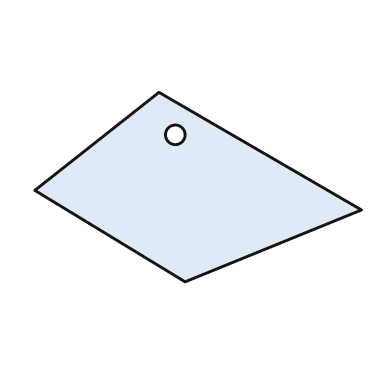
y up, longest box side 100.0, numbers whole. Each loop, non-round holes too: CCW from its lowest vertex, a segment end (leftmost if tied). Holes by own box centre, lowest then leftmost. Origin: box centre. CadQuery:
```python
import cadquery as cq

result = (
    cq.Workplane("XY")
    .moveTo(-4.0, -29.0)
    .lineTo(50.0, -7.0)
    .lineTo(-12.0, 29.0)
    .lineTo(-50.0, -1.0)
    .close()
    .moveTo(-7.0, 16.0)
    .circle(3.0)
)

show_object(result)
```